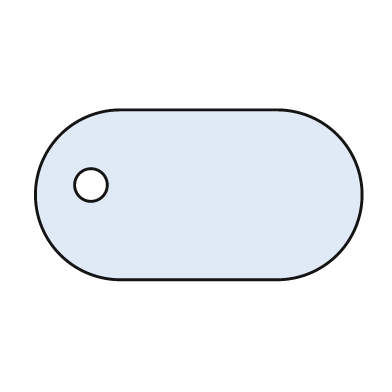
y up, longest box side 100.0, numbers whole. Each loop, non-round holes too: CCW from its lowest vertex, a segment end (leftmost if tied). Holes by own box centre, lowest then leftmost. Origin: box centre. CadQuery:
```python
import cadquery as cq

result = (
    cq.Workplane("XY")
    .moveTo(-24.0, -26.0)
    .lineTo(24.0, -26.0)
    .threePointArc((50.0, 0.0), (24.0, 26.0))
    .lineTo(-24.0, 26.0)
    .threePointArc((-50.0, 0.0), (-24.0, -26.0))
    .close()
    .moveTo(-33.0, 3.0)
    .circle(5.0)
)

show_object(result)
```